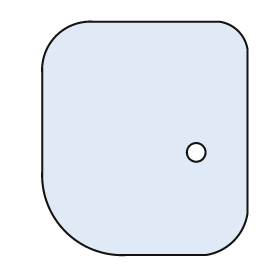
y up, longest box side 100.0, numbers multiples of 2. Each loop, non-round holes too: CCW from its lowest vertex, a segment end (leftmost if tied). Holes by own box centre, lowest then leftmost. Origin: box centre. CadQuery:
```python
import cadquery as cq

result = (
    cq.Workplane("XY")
    .moveTo(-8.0, -50.0)
    .lineTo(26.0, -50.0)
    .threePointArc((38.0, -44.0), (44.0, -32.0))
    .lineTo(44.0, 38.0)
    .threePointArc((40.0, 46.0), (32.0, 50.0))
    .lineTo(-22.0, 50.0)
    .threePointArc((-38.0, 44.0), (-44.0, 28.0))
    .lineTo(-44.0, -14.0)
    .threePointArc((-34.0, -40.0), (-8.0, -50.0))
    .close()
    .moveTo(22.0, -6.0)
    .circle(4.0)
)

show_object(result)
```